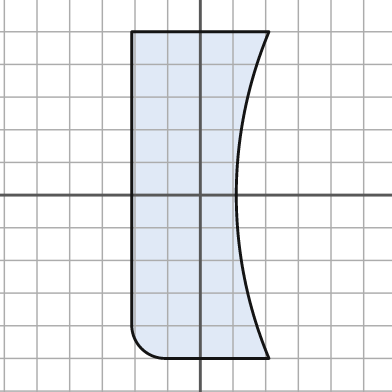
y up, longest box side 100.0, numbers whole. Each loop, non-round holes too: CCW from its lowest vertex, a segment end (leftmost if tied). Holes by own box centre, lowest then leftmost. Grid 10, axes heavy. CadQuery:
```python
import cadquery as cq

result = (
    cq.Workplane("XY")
    .moveTo(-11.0, -50.0)
    .lineTo(21.0, -50.0)
    .threePointArc((11.0, 0.0), (21.0, 50.0))
    .lineTo(-21.0, 50.0)
    .lineTo(-21.0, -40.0)
    .threePointArc((-18.0, -47.0), (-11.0, -50.0))
    .close()
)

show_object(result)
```